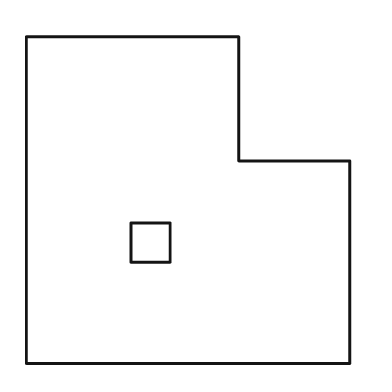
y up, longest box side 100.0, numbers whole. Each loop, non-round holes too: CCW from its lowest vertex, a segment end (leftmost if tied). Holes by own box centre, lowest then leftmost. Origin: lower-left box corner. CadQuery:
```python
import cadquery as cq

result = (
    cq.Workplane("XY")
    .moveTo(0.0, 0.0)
    .lineTo(99.0, 0.0)
    .lineTo(99.0, 62.0)
    .lineTo(65.0, 62.0)
    .lineTo(65.0, 100.0)
    .lineTo(0.0, 100.0)
    .close()
    .moveTo(32.0, 31.0)
    .lineTo(44.0, 31.0)
    .lineTo(44.0, 43.0)
    .lineTo(32.0, 43.0)
    .close()
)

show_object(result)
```